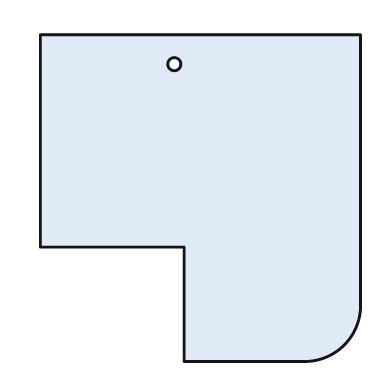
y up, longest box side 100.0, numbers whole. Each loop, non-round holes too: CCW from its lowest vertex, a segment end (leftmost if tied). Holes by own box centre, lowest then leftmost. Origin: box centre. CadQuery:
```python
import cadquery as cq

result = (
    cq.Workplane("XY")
    .moveTo(-5.0, -50.0)
    .lineTo(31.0, -50.0)
    .threePointArc((44.0, -45.0), (49.0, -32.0))
    .lineTo(49.0, 50.0)
    .lineTo(-49.0, 50.0)
    .lineTo(-49.0, -15.0)
    .lineTo(-5.0, -15.0)
    .close()
    .moveTo(-8.0, 41.0)
    .circle(2.0)
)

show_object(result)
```